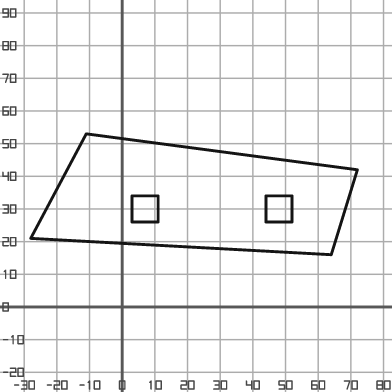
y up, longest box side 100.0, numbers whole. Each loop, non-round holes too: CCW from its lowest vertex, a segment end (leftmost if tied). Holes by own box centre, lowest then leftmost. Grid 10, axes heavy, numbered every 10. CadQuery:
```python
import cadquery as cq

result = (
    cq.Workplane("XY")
    .moveTo(64.0, 16.0)
    .lineTo(72.0, 42.0)
    .lineTo(-11.0, 53.0)
    .lineTo(-28.0, 21.0)
    .close()
    .moveTo(3.0, 26.0)
    .lineTo(11.0, 26.0)
    .lineTo(11.0, 34.0)
    .lineTo(3.0, 34.0)
    .close()
    .moveTo(44.0, 26.0)
    .lineTo(52.0, 26.0)
    .lineTo(52.0, 34.0)
    .lineTo(44.0, 34.0)
    .close()
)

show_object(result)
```